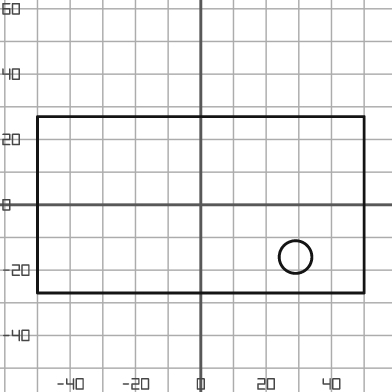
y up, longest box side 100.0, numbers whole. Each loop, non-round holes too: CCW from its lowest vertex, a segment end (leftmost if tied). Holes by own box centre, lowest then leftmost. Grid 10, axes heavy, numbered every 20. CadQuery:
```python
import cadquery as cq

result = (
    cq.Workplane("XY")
    .moveTo(-50.0, -27.0)
    .lineTo(50.0, -27.0)
    .lineTo(50.0, 27.0)
    .lineTo(-50.0, 27.0)
    .close()
    .moveTo(29.0, -16.0)
    .circle(5.0)
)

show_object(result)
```